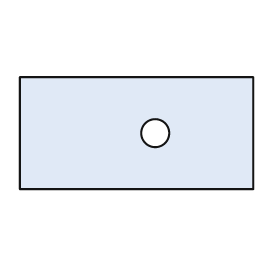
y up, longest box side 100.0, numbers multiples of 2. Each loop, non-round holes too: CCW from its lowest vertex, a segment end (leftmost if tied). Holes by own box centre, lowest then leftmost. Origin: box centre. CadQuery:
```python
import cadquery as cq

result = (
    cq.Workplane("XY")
    .moveTo(-50.0, -24.0)
    .lineTo(50.0, -24.0)
    .lineTo(50.0, 24.0)
    .lineTo(-50.0, 24.0)
    .close()
    .moveTo(8.0, 0.0)
    .circle(6.0)
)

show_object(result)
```